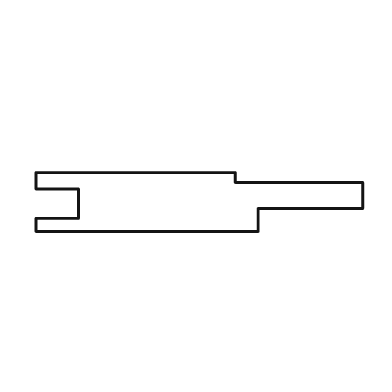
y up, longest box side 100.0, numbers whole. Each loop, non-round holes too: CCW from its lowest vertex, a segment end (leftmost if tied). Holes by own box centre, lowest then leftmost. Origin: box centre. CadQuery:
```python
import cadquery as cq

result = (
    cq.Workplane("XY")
    .moveTo(-50.0, -9.0)
    .lineTo(18.0, -9.0)
    .lineTo(18.0, -2.0)
    .lineTo(50.0, -2.0)
    .lineTo(50.0, 6.0)
    .lineTo(11.0, 6.0)
    .lineTo(11.0, 9.0)
    .lineTo(-50.0, 9.0)
    .lineTo(-50.0, 4.0)
    .lineTo(-37.0, 4.0)
    .lineTo(-37.0, -5.0)
    .lineTo(-50.0, -5.0)
    .close()
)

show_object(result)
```